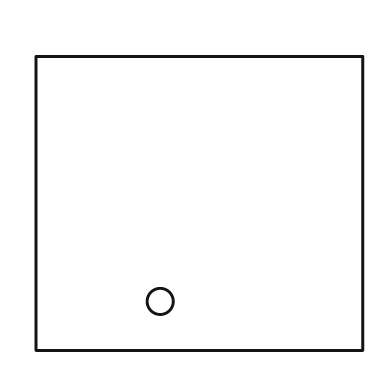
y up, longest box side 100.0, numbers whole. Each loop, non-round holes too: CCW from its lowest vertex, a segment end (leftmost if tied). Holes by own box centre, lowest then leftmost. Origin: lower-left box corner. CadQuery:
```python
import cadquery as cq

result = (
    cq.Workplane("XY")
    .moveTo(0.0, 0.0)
    .lineTo(100.0, 0.0)
    .lineTo(100.0, 90.0)
    .lineTo(0.0, 90.0)
    .close()
    .moveTo(38.0, 15.0)
    .circle(4.0)
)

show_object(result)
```